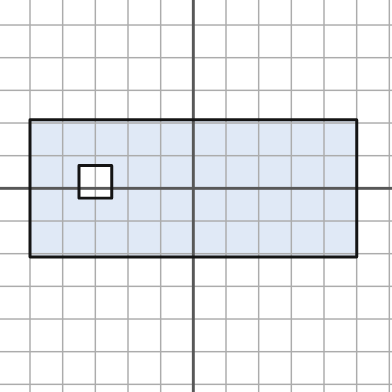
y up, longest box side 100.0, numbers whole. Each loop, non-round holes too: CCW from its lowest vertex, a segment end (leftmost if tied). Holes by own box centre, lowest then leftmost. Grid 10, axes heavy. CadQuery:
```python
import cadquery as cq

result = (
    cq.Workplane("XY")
    .moveTo(-50.0, -21.0)
    .lineTo(50.0, -21.0)
    .lineTo(50.0, 21.0)
    .lineTo(-50.0, 21.0)
    .close()
    .moveTo(-35.0, -3.0)
    .lineTo(-25.0, -3.0)
    .lineTo(-25.0, 7.0)
    .lineTo(-35.0, 7.0)
    .close()
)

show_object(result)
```